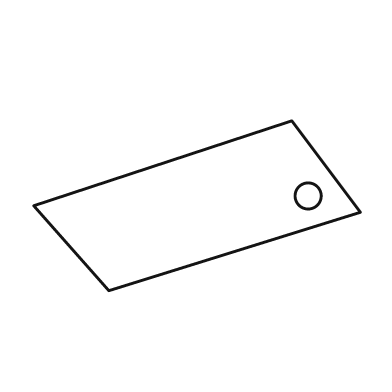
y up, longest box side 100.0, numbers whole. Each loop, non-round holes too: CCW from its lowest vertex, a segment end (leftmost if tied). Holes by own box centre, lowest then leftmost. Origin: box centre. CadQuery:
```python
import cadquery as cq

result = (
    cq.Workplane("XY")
    .moveTo(-27.0, -26.0)
    .lineTo(50.0, -2.0)
    .lineTo(29.0, 26.0)
    .lineTo(-50.0, 0.0)
    .close()
    .moveTo(34.0, 3.0)
    .circle(4.0)
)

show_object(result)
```